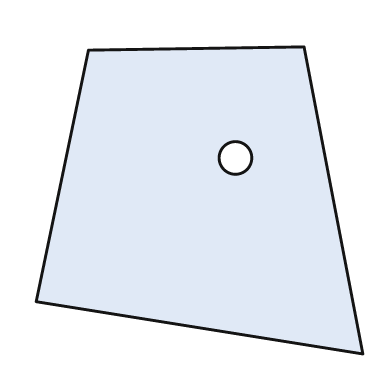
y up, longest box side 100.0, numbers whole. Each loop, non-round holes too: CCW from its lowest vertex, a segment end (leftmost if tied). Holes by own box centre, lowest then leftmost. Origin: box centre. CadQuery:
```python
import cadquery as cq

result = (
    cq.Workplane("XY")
    .moveTo(50.0, -47.0)
    .lineTo(32.0, 47.0)
    .lineTo(-34.0, 46.0)
    .lineTo(-50.0, -31.0)
    .close()
    .moveTo(11.0, 13.0)
    .circle(5.0)
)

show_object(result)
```